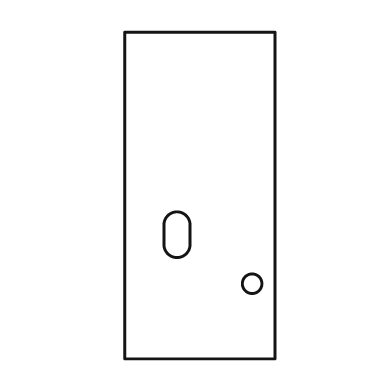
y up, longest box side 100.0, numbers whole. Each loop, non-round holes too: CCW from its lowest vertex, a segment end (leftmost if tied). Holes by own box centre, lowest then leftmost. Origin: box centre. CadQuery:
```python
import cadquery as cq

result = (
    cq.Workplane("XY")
    .moveTo(-23.0, -50.0)
    .lineTo(23.0, -50.0)
    .lineTo(23.0, 50.0)
    .lineTo(-23.0, 50.0)
    .close()
    .moveTo(16.0, -27.0)
    .circle(3.0)
    .moveTo(-11.0, -15.0)
    .threePointArc((-7.0, -19.0), (-3.0, -15.0))
    .lineTo(-3.0, -9.0)
    .threePointArc((-7.0, -5.0), (-11.0, -9.0))
    .close()
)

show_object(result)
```